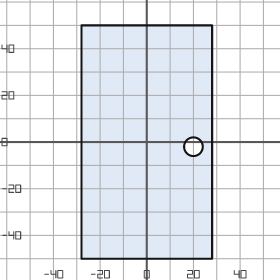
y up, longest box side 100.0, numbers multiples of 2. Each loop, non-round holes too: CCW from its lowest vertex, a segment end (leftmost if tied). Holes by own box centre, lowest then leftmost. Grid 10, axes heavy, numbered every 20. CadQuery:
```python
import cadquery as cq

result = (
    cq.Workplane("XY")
    .moveTo(-28.0, -50.0)
    .lineTo(28.0, -50.0)
    .lineTo(28.0, 50.0)
    .lineTo(-28.0, 50.0)
    .close()
    .moveTo(20.0, -2.0)
    .circle(4.0)
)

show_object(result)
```